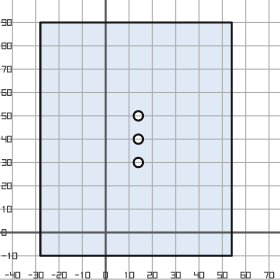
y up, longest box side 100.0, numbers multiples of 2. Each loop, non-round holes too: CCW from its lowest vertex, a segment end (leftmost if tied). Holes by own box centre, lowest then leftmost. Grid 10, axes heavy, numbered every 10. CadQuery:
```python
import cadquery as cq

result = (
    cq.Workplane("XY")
    .moveTo(-28.0, -10.0)
    .lineTo(54.0, -10.0)
    .lineTo(54.0, 90.0)
    .lineTo(-28.0, 90.0)
    .close()
    .moveTo(14.0, 30.0)
    .circle(2.0)
    .moveTo(14.0, 40.0)
    .circle(2.0)
    .moveTo(14.0, 50.0)
    .circle(2.0)
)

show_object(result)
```